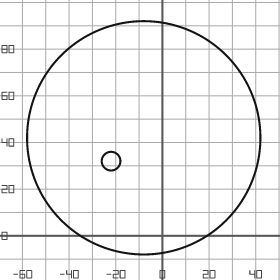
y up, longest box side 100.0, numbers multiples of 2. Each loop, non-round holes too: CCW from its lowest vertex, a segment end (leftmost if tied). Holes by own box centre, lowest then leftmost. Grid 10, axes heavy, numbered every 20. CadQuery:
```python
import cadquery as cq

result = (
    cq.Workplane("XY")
    .moveTo(-8.0, 42.0)
    .circle(50.0)
    .moveTo(-22.0, 32.0)
    .circle(4.0)
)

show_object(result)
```